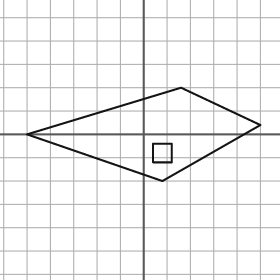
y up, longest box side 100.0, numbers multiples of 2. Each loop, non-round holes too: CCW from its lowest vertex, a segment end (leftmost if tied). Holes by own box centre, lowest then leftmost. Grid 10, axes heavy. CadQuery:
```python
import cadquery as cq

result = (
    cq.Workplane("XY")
    .moveTo(8.0, -20.0)
    .lineTo(50.0, 4.0)
    .lineTo(16.0, 20.0)
    .lineTo(-50.0, 0.0)
    .close()
    .moveTo(4.0, -12.0)
    .lineTo(12.0, -12.0)
    .lineTo(12.0, -4.0)
    .lineTo(4.0, -4.0)
    .close()
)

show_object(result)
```